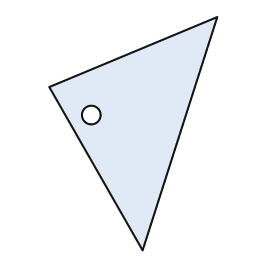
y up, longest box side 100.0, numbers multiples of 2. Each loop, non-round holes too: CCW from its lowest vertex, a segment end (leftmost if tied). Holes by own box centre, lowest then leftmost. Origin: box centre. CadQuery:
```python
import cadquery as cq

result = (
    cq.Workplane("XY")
    .moveTo(4.0, -50.0)
    .lineTo(36.0, 50.0)
    .lineTo(-36.0, 20.0)
    .close()
    .moveTo(-18.0, 8.0)
    .circle(4.0)
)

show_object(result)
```